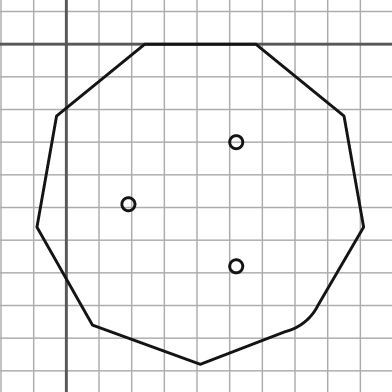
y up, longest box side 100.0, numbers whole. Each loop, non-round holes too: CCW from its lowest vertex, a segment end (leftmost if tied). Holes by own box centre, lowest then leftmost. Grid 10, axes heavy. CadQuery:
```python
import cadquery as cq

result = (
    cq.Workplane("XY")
    .moveTo(41.0, -98.0)
    .lineTo(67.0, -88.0)
    .threePointArc((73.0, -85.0), (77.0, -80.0))
    .lineTo(91.0, -56.0)
    .lineTo(85.0, -22.0)
    .lineTo(58.0, 0.0)
    .lineTo(24.0, 0.0)
    .lineTo(-3.0, -22.0)
    .lineTo(-9.0, -56.0)
    .lineTo(8.0, -86.0)
    .close()
    .moveTo(52.0, -68.0)
    .circle(2.0)
    .moveTo(19.0, -49.0)
    .circle(2.0)
    .moveTo(52.0, -30.0)
    .circle(2.0)
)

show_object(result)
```